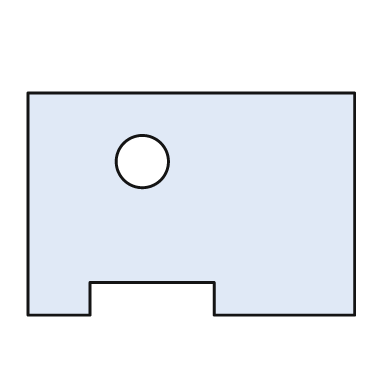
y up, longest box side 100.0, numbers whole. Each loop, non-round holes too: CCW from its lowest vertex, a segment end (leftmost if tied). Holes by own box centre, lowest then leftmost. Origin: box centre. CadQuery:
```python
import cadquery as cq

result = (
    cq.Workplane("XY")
    .moveTo(-50.0, -34.0)
    .lineTo(-31.0, -34.0)
    .lineTo(-31.0, -24.0)
    .lineTo(7.0, -24.0)
    .lineTo(7.0, -34.0)
    .lineTo(50.0, -34.0)
    .lineTo(50.0, 34.0)
    .lineTo(-50.0, 34.0)
    .close()
    .moveTo(-15.0, 13.0)
    .circle(8.0)
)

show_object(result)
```